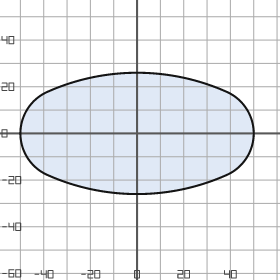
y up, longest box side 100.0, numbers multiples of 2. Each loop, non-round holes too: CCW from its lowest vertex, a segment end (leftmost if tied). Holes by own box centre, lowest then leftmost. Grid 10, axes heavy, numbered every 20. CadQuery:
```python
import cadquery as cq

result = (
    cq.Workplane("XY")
    .moveTo(-38.0, -18.0)
    .threePointArc((0.0, -26.0), (38.0, -18.0))
    .threePointArc((50.0, 0.0), (38.0, 18.0))
    .threePointArc((0.0, 26.0), (-38.0, 18.0))
    .threePointArc((-50.0, 0.0), (-38.0, -18.0))
    .close()
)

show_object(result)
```